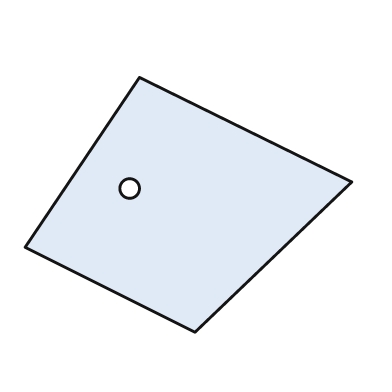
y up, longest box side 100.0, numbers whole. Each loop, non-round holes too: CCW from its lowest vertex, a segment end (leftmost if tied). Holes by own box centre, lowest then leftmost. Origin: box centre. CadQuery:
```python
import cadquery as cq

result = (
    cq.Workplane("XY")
    .moveTo(2.0, -39.0)
    .lineTo(50.0, 7.0)
    .lineTo(-15.0, 39.0)
    .lineTo(-50.0, -13.0)
    .close()
    .moveTo(-18.0, 5.0)
    .circle(3.0)
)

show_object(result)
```